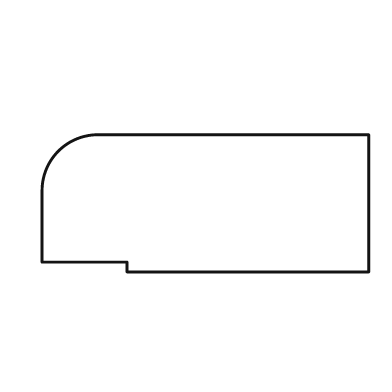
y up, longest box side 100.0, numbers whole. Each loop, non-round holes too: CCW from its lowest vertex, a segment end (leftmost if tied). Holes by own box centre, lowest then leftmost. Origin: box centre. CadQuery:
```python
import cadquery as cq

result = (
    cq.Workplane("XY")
    .moveTo(-24.0, -21.0)
    .lineTo(50.0, -21.0)
    .lineTo(50.0, 21.0)
    .lineTo(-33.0, 21.0)
    .threePointArc((-45.0, 16.0), (-50.0, 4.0))
    .lineTo(-50.0, -18.0)
    .lineTo(-24.0, -18.0)
    .close()
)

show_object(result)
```